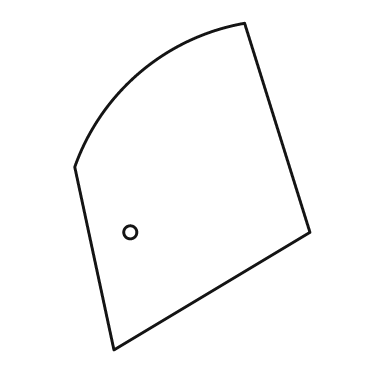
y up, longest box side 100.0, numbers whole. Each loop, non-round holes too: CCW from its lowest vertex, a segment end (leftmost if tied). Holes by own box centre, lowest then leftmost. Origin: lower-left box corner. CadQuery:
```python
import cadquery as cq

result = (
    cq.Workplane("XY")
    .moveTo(12.0, 0.0)
    .lineTo(72.0, 36.0)
    .lineTo(52.0, 100.0)
    .threePointArc((20.0, 85.0), (0.0, 56.0))
    .close()
    .moveTo(17.0, 36.0)
    .circle(2.0)
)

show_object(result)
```